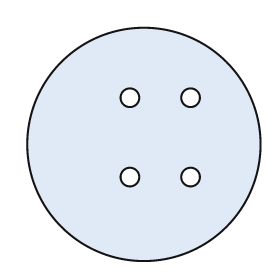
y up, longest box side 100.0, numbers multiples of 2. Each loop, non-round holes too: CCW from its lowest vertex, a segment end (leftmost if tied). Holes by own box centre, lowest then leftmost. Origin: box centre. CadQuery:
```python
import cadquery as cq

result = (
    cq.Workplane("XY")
    .moveTo(0.0, 0.0)
    .circle(50.0)
    .moveTo(-6.0, -14.0)
    .circle(4.0)
    .moveTo(20.0, -14.0)
    .circle(4.0)
    .moveTo(-6.0, 20.0)
    .circle(4.0)
    .moveTo(20.0, 20.0)
    .circle(4.0)
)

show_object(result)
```